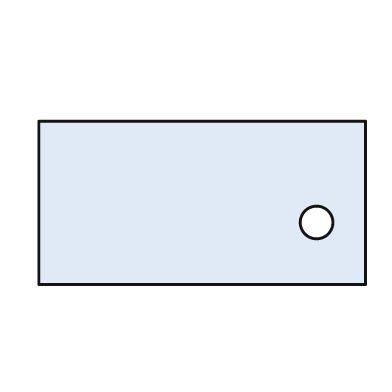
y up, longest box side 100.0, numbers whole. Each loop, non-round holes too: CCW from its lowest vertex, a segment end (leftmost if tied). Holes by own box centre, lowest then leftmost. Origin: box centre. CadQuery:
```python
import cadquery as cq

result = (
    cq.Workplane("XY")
    .moveTo(-50.0, -25.0)
    .lineTo(50.0, -25.0)
    .lineTo(50.0, 25.0)
    .lineTo(-50.0, 25.0)
    .close()
    .moveTo(35.0, -6.0)
    .circle(5.0)
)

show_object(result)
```